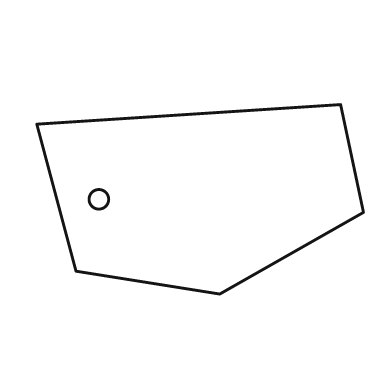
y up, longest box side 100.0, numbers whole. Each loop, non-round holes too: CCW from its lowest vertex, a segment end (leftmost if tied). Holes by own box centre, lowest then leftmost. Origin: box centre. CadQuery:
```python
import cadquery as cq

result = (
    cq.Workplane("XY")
    .moveTo(6.0, -29.0)
    .lineTo(50.0, -4.0)
    .lineTo(43.0, 29.0)
    .lineTo(-50.0, 23.0)
    .lineTo(-38.0, -22.0)
    .close()
    .moveTo(-31.0, 0.0)
    .circle(3.0)
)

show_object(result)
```